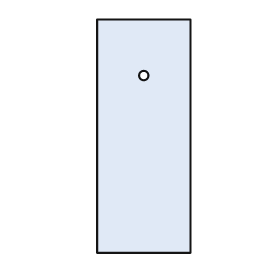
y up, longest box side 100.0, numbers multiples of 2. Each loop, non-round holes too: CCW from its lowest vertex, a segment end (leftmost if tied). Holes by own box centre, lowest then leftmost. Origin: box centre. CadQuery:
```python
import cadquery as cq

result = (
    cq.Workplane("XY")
    .moveTo(-20.0, -50.0)
    .lineTo(20.0, -50.0)
    .lineTo(20.0, 50.0)
    .lineTo(-20.0, 50.0)
    .close()
    .moveTo(0.0, 26.0)
    .circle(2.0)
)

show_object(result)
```